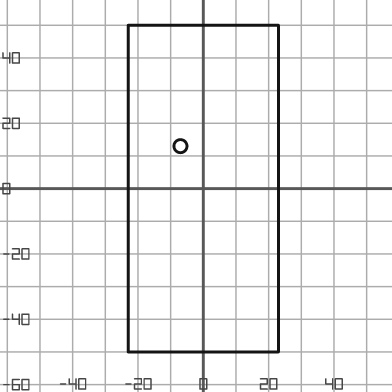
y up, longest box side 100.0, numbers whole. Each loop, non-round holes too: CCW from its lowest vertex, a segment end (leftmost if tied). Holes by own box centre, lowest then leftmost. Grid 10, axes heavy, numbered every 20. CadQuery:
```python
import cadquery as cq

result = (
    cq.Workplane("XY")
    .moveTo(-23.0, -50.0)
    .lineTo(23.0, -50.0)
    .lineTo(23.0, 50.0)
    .lineTo(-23.0, 50.0)
    .close()
    .moveTo(-7.0, 13.0)
    .circle(2.0)
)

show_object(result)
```